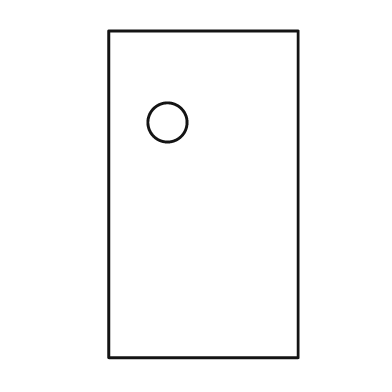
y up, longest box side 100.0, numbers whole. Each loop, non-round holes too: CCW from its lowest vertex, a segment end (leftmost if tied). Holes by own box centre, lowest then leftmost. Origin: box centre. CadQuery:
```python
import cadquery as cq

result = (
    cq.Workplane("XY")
    .moveTo(-29.0, -50.0)
    .lineTo(29.0, -50.0)
    .lineTo(29.0, 50.0)
    .lineTo(-29.0, 50.0)
    .close()
    .moveTo(-11.0, 22.0)
    .circle(6.0)
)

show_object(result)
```